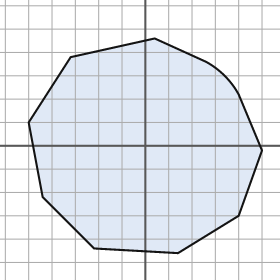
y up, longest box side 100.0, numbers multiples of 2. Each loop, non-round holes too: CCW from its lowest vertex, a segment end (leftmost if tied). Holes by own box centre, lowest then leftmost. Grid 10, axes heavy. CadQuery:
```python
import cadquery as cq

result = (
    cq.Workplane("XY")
    .moveTo(14.0, -46.0)
    .lineTo(40.0, -30.0)
    .lineTo(50.0, -2.0)
    .lineTo(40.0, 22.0)
    .threePointArc((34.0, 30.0), (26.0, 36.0))
    .lineTo(4.0, 46.0)
    .lineTo(-32.0, 38.0)
    .lineTo(-50.0, 10.0)
    .lineTo(-44.0, -22.0)
    .lineTo(-22.0, -44.0)
    .close()
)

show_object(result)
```